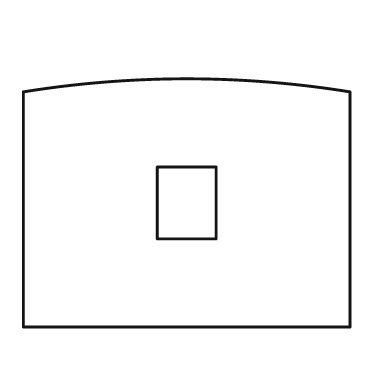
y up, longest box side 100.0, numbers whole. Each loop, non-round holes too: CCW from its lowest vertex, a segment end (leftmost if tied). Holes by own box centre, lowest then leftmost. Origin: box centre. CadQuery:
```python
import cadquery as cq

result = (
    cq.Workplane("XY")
    .moveTo(-50.0, -38.0)
    .lineTo(50.0, -38.0)
    .lineTo(50.0, 34.0)
    .threePointArc((0.0, 38.0), (-50.0, 34.0))
    .close()
    .moveTo(-9.0, -11.0)
    .lineTo(9.0, -11.0)
    .lineTo(9.0, 11.0)
    .lineTo(-9.0, 11.0)
    .close()
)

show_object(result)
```